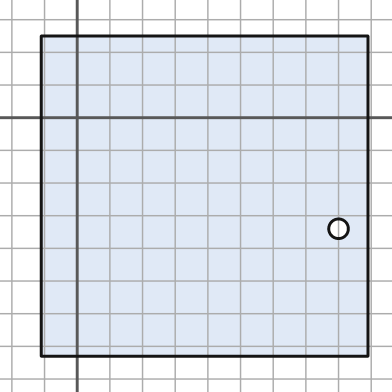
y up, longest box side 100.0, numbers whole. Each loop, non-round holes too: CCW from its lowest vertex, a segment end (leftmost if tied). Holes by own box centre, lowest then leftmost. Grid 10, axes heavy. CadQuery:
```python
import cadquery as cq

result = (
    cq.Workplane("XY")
    .moveTo(-11.0, -73.0)
    .lineTo(89.0, -73.0)
    .lineTo(89.0, 25.0)
    .lineTo(-11.0, 25.0)
    .close()
    .moveTo(80.0, -34.0)
    .circle(3.0)
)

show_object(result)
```